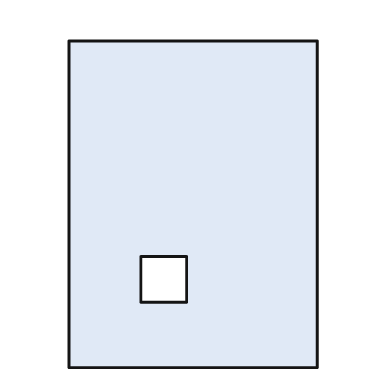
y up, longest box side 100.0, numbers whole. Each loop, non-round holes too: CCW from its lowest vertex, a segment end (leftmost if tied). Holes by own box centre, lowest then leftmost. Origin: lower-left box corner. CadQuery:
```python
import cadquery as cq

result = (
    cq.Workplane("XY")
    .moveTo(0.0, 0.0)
    .lineTo(76.0, 0.0)
    .lineTo(76.0, 100.0)
    .lineTo(0.0, 100.0)
    .close()
    .moveTo(22.0, 20.0)
    .lineTo(36.0, 20.0)
    .lineTo(36.0, 34.0)
    .lineTo(22.0, 34.0)
    .close()
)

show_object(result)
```